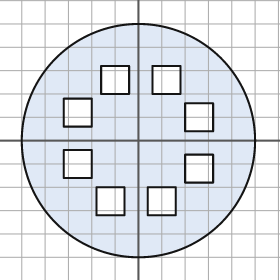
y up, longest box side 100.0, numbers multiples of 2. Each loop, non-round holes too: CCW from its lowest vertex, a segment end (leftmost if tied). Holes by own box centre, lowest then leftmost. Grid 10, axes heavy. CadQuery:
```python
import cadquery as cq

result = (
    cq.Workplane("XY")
    .moveTo(0.0, 0.0)
    .circle(50.0)
    .moveTo(-18.0, -32.0)
    .lineTo(-6.0, -32.0)
    .lineTo(-6.0, -20.0)
    .lineTo(-18.0, -20.0)
    .close()
    .moveTo(4.0, -32.0)
    .lineTo(16.0, -32.0)
    .lineTo(16.0, -20.0)
    .lineTo(4.0, -20.0)
    .close()
    .moveTo(20.0, -18.0)
    .lineTo(32.0, -18.0)
    .lineTo(32.0, -6.0)
    .lineTo(20.0, -6.0)
    .close()
    .moveTo(-32.0, -16.0)
    .lineTo(-20.0, -16.0)
    .lineTo(-20.0, -4.0)
    .lineTo(-32.0, -4.0)
    .close()
    .moveTo(20.0, 4.0)
    .lineTo(32.0, 4.0)
    .lineTo(32.0, 16.0)
    .lineTo(20.0, 16.0)
    .close()
    .moveTo(-32.0, 6.0)
    .lineTo(-20.0, 6.0)
    .lineTo(-20.0, 18.0)
    .lineTo(-32.0, 18.0)
    .close()
    .moveTo(-16.0, 20.0)
    .lineTo(-4.0, 20.0)
    .lineTo(-4.0, 32.0)
    .lineTo(-16.0, 32.0)
    .close()
    .moveTo(6.0, 20.0)
    .lineTo(18.0, 20.0)
    .lineTo(18.0, 32.0)
    .lineTo(6.0, 32.0)
    .close()
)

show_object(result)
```